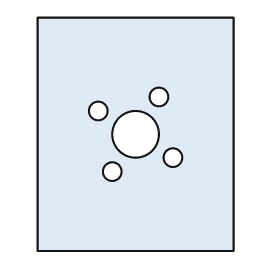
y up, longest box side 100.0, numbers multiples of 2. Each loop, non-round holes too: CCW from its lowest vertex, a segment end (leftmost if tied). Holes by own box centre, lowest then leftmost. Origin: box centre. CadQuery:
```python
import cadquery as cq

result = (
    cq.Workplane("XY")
    .moveTo(-42.0, -50.0)
    .lineTo(42.0, -50.0)
    .lineTo(42.0, 50.0)
    .lineTo(-42.0, 50.0)
    .close()
    .moveTo(-10.0, -16.0)
    .circle(4.0)
    .moveTo(16.0, -10.0)
    .circle(4.0)
    .moveTo(0.0, 0.0)
    .circle(10.0)
    .moveTo(-16.0, 10.0)
    .circle(4.0)
    .moveTo(10.0, 16.0)
    .circle(4.0)
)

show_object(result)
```